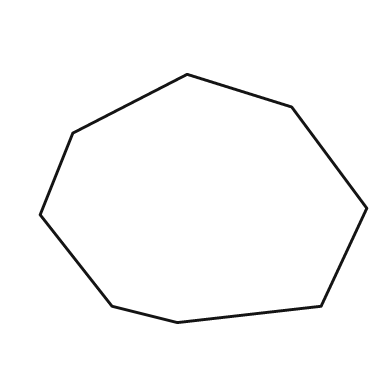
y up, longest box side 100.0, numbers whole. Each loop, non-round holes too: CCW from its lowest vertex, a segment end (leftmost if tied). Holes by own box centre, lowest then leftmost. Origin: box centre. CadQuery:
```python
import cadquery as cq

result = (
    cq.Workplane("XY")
    .moveTo(-8.0, -38.0)
    .lineTo(36.0, -33.0)
    .lineTo(50.0, -3.0)
    .lineTo(27.0, 28.0)
    .lineTo(-5.0, 38.0)
    .lineTo(-40.0, 20.0)
    .lineTo(-50.0, -5.0)
    .lineTo(-28.0, -33.0)
    .close()
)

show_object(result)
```